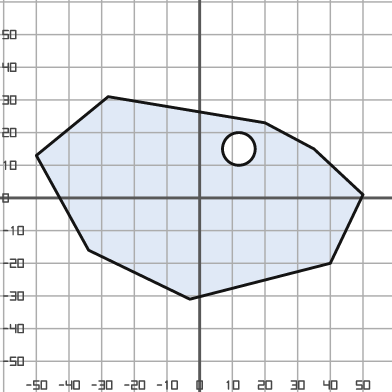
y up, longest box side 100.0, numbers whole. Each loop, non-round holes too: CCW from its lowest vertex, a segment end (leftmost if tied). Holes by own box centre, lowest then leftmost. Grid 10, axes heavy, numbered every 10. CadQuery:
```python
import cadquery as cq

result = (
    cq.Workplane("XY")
    .moveTo(-3.0, -31.0)
    .lineTo(40.0, -20.0)
    .lineTo(50.0, 1.0)
    .lineTo(35.0, 15.0)
    .lineTo(20.0, 23.0)
    .lineTo(-28.0, 31.0)
    .lineTo(-50.0, 13.0)
    .lineTo(-34.0, -16.0)
    .close()
    .moveTo(12.0, 15.0)
    .circle(5.0)
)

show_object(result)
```